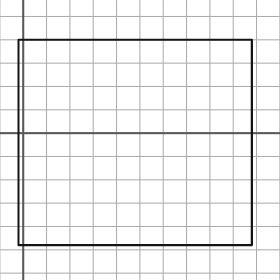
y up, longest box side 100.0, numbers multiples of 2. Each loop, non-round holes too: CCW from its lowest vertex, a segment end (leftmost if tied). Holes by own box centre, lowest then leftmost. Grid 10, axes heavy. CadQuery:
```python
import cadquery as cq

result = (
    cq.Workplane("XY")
    .moveTo(-2.0, -48.0)
    .lineTo(98.0, -48.0)
    .lineTo(98.0, 40.0)
    .lineTo(-2.0, 40.0)
    .close()
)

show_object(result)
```